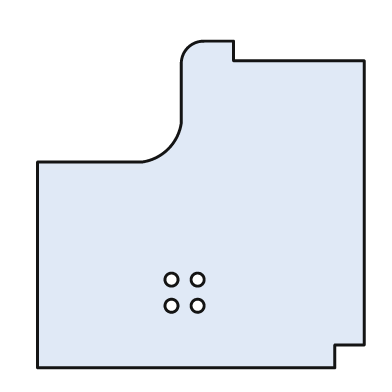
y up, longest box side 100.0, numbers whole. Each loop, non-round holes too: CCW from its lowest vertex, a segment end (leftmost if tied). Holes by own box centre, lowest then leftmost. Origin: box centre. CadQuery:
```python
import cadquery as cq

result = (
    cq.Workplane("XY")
    .moveTo(-50.0, -50.0)
    .lineTo(41.0, -50.0)
    .lineTo(41.0, -43.0)
    .lineTo(50.0, -43.0)
    .lineTo(50.0, 44.0)
    .lineTo(10.0, 44.0)
    .lineTo(10.0, 50.0)
    .lineTo(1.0, 50.0)
    .threePointArc((-4.0, 48.0), (-6.0, 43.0))
    .lineTo(-6.0, 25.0)
    .threePointArc((-10.0, 17.0), (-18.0, 13.0))
    .lineTo(-50.0, 13.0)
    .close()
    .moveTo(-9.0, -31.0)
    .circle(2.0)
    .moveTo(-1.0, -31.0)
    .circle(2.0)
    .moveTo(-9.0, -23.0)
    .circle(2.0)
    .moveTo(-1.0, -23.0)
    .circle(2.0)
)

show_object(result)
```